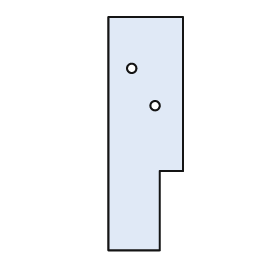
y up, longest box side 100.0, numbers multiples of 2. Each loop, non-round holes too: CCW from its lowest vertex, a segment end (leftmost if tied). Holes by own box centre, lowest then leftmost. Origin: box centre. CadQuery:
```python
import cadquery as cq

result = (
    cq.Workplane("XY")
    .moveTo(-16.0, -50.0)
    .lineTo(6.0, -50.0)
    .lineTo(6.0, -16.0)
    .lineTo(16.0, -16.0)
    .lineTo(16.0, 50.0)
    .lineTo(-16.0, 50.0)
    .close()
    .moveTo(4.0, 12.0)
    .circle(2.0)
    .moveTo(-6.0, 28.0)
    .circle(2.0)
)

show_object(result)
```